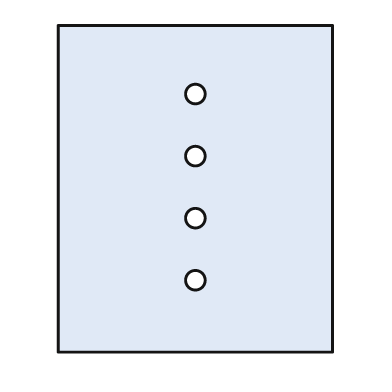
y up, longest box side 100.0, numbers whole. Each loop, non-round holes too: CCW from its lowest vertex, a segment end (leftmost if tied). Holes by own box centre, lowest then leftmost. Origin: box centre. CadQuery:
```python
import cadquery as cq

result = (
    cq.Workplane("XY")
    .moveTo(-42.0, -50.0)
    .lineTo(42.0, -50.0)
    .lineTo(42.0, 50.0)
    .lineTo(-42.0, 50.0)
    .close()
    .moveTo(0.0, -28.0)
    .circle(3.0)
    .moveTo(0.0, -9.0)
    .circle(3.0)
    .moveTo(0.0, 10.0)
    .circle(3.0)
    .moveTo(0.0, 29.0)
    .circle(3.0)
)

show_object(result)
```